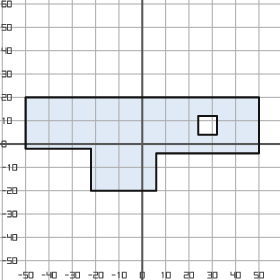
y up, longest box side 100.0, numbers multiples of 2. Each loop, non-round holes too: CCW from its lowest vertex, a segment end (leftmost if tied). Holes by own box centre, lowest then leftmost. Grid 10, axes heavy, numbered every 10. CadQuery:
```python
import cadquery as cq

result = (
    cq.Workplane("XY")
    .moveTo(-22.0, -20.0)
    .lineTo(6.0, -20.0)
    .lineTo(6.0, -4.0)
    .lineTo(50.0, -4.0)
    .lineTo(50.0, 20.0)
    .lineTo(-50.0, 20.0)
    .lineTo(-50.0, -2.0)
    .lineTo(-22.0, -2.0)
    .close()
    .moveTo(24.0, 4.0)
    .lineTo(32.0, 4.0)
    .lineTo(32.0, 12.0)
    .lineTo(24.0, 12.0)
    .close()
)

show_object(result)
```